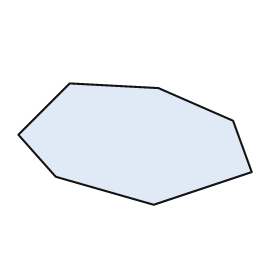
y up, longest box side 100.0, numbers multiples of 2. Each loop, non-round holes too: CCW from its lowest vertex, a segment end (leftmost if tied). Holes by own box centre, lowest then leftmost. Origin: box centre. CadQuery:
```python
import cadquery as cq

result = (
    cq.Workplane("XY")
    .moveTo(8.0, -26.0)
    .lineTo(50.0, -12.0)
    .lineTo(42.0, 10.0)
    .lineTo(10.0, 24.0)
    .lineTo(-28.0, 26.0)
    .lineTo(-50.0, 4.0)
    .lineTo(-34.0, -14.0)
    .close()
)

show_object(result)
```